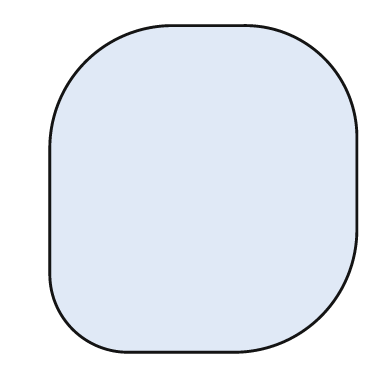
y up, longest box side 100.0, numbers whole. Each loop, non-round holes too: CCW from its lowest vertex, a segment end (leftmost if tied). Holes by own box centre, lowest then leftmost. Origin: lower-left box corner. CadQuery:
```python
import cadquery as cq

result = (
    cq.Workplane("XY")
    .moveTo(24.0, 0.0)
    .lineTo(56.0, 0.0)
    .threePointArc((83.0, 11.0), (94.0, 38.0))
    .lineTo(94.0, 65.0)
    .threePointArc((84.0, 90.0), (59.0, 100.0))
    .lineTo(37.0, 100.0)
    .threePointArc((11.0, 89.0), (0.0, 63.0))
    .lineTo(0.0, 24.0)
    .threePointArc((7.0, 7.0), (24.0, 0.0))
    .close()
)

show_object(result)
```